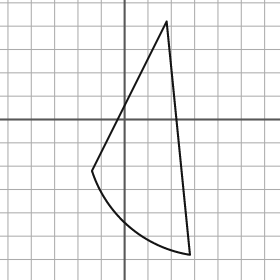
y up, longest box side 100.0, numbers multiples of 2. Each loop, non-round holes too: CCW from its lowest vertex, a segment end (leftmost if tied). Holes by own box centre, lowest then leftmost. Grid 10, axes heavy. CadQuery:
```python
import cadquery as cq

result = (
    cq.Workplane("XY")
    .moveTo(28.0, -58.0)
    .lineTo(18.0, 42.0)
    .lineTo(-14.0, -22.0)
    .threePointArc((2.0, -46.0), (28.0, -58.0))
    .close()
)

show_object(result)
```